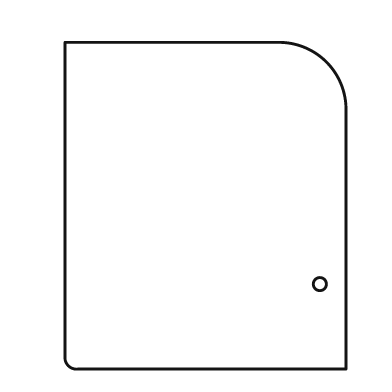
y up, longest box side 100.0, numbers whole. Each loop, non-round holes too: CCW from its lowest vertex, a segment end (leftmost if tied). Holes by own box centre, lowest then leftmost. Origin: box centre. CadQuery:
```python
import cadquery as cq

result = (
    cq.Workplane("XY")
    .moveTo(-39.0, -50.0)
    .lineTo(43.0, -50.0)
    .lineTo(43.0, 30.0)
    .threePointArc((37.0, 44.0), (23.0, 50.0))
    .lineTo(-43.0, 50.0)
    .lineTo(-43.0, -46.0)
    .threePointArc((-42.0, -49.0), (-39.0, -50.0))
    .close()
    .moveTo(35.0, -24.0)
    .circle(2.0)
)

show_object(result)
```